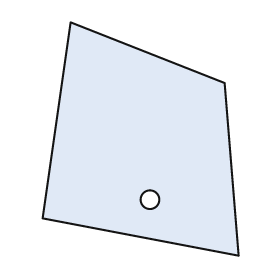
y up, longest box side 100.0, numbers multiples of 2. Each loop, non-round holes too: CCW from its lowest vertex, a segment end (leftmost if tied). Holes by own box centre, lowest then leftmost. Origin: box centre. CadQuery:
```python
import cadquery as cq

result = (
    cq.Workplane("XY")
    .moveTo(42.0, -50.0)
    .lineTo(36.0, 24.0)
    .lineTo(-30.0, 50.0)
    .lineTo(-42.0, -34.0)
    .close()
    .moveTo(4.0, -26.0)
    .circle(4.0)
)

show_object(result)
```